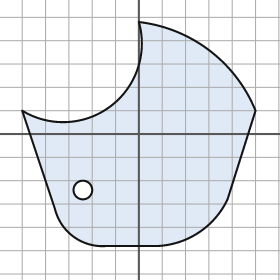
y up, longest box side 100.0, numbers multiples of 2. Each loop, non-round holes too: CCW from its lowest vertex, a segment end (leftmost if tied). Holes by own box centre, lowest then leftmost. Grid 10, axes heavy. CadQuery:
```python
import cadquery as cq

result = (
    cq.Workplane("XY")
    .moveTo(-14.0, -48.0)
    .lineTo(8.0, -48.0)
    .threePointArc((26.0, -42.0), (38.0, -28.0))
    .lineTo(50.0, 10.0)
    .threePointArc((30.0, 36.0), (0.0, 48.0))
    .threePointArc((-12.0, 12.0), (-50.0, 10.0))
    .lineTo(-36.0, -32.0)
    .threePointArc((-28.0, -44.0), (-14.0, -48.0))
    .close()
    .moveTo(-24.0, -24.0)
    .circle(4.0)
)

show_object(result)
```